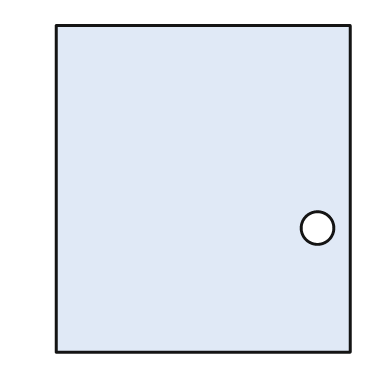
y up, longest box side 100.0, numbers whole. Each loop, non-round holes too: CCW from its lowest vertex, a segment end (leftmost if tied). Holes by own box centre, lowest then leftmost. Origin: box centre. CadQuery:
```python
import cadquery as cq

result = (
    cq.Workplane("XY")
    .moveTo(-45.0, -50.0)
    .lineTo(45.0, -50.0)
    .lineTo(45.0, 50.0)
    .lineTo(-45.0, 50.0)
    .close()
    .moveTo(35.0, -12.0)
    .circle(5.0)
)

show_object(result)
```